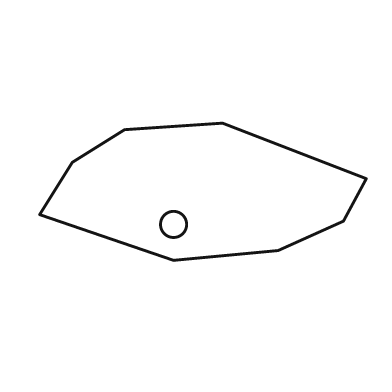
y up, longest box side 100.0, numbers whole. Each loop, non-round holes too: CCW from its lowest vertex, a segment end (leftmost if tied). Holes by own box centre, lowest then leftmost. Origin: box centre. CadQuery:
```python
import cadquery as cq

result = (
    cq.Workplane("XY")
    .moveTo(-9.0, -21.0)
    .lineTo(23.0, -18.0)
    .lineTo(43.0, -9.0)
    .lineTo(50.0, 4.0)
    .lineTo(6.0, 21.0)
    .lineTo(-24.0, 19.0)
    .lineTo(-40.0, 9.0)
    .lineTo(-50.0, -7.0)
    .close()
    .moveTo(-9.0, -10.0)
    .circle(4.0)
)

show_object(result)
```